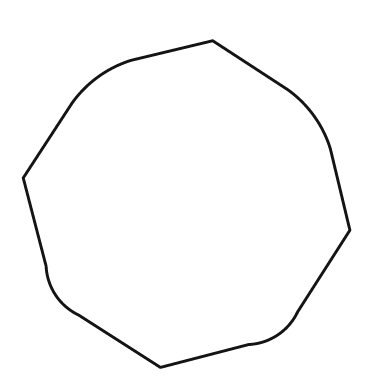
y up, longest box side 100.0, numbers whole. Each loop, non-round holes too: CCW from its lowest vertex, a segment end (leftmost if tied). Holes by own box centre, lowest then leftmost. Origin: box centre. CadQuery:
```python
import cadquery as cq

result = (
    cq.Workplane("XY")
    .moveTo(-8.0, -50.0)
    .lineTo(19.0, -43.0)
    .threePointArc((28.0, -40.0), (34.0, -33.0))
    .lineTo(50.0, -8.0)
    .lineTo(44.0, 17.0)
    .threePointArc((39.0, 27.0), (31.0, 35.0))
    .lineTo(8.0, 50.0)
    .lineTo(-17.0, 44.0)
    .threePointArc((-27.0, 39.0), (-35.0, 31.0))
    .lineTo(-50.0, 8.0)
    .lineTo(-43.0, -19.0)
    .threePointArc((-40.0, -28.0), (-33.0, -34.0))
    .close()
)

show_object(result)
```